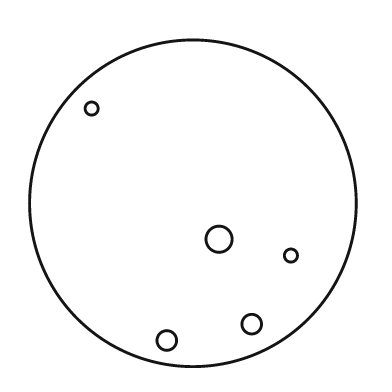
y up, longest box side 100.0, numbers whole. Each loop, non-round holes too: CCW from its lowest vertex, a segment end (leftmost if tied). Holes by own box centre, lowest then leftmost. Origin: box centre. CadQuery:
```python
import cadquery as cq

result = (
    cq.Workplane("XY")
    .moveTo(0.0, 0.0)
    .circle(50.0)
    .moveTo(-8.0, -42.0)
    .circle(3.0)
    .moveTo(18.0, -37.0)
    .circle(3.0)
    .moveTo(30.0, -16.0)
    .circle(2.0)
    .moveTo(8.0, -11.0)
    .circle(4.0)
    .moveTo(-31.0, 29.0)
    .circle(2.0)
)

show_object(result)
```